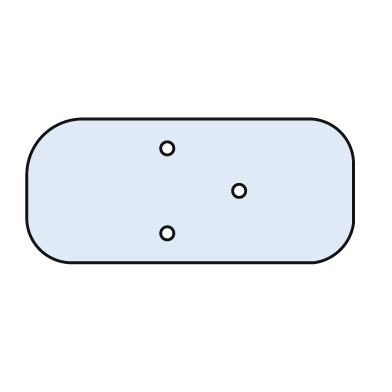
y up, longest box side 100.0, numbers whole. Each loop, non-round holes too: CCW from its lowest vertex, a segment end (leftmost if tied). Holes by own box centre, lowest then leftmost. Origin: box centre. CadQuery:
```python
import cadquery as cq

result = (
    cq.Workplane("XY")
    .moveTo(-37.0, -22.0)
    .lineTo(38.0, -22.0)
    .threePointArc((46.0, -18.0), (50.0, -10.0))
    .lineTo(50.0, 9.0)
    .threePointArc((46.0, 18.0), (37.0, 22.0))
    .lineTo(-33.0, 22.0)
    .threePointArc((-45.0, 17.0), (-50.0, 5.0))
    .lineTo(-50.0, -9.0)
    .threePointArc((-46.0, -18.0), (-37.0, -22.0))
    .close()
    .moveTo(-7.0, -13.0)
    .circle(2.0)
    .moveTo(15.0, 0.0)
    .circle(2.0)
    .moveTo(-7.0, 13.0)
    .circle(2.0)
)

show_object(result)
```